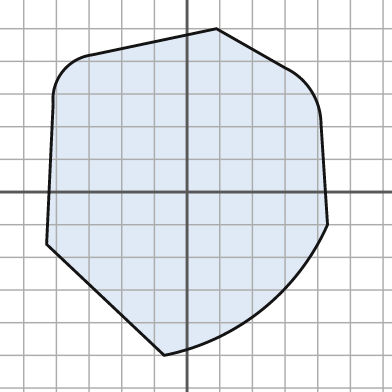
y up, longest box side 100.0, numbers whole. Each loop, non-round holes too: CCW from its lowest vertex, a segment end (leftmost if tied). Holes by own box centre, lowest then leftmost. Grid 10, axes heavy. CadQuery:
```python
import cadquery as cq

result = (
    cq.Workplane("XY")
    .moveTo(-7.0, -50.0)
    .threePointArc((23.0, -36.0), (43.0, -10.0))
    .lineTo(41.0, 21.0)
    .threePointArc((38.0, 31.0), (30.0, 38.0))
    .lineTo(9.0, 50.0)
    .lineTo(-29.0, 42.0)
    .threePointArc((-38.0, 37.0), (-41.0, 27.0))
    .lineTo(-43.0, -16.0)
    .close()
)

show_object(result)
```